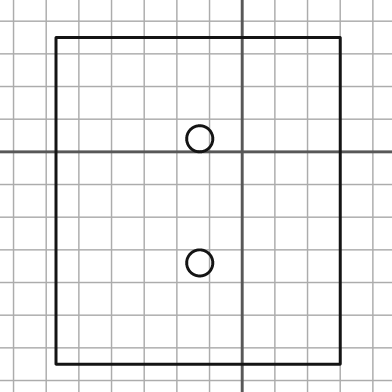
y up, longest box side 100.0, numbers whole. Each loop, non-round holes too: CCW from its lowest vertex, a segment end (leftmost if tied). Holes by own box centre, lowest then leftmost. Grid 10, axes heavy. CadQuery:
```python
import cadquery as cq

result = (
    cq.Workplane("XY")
    .moveTo(-57.0, -65.0)
    .lineTo(30.0, -65.0)
    .lineTo(30.0, 35.0)
    .lineTo(-57.0, 35.0)
    .close()
    .moveTo(-13.0, -34.0)
    .circle(4.0)
    .moveTo(-13.0, 4.0)
    .circle(4.0)
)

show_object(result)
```